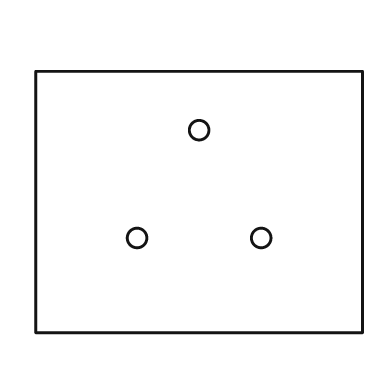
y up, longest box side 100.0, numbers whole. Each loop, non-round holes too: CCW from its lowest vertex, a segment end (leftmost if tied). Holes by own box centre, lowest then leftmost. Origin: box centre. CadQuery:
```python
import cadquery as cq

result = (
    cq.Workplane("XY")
    .moveTo(-50.0, -40.0)
    .lineTo(50.0, -40.0)
    .lineTo(50.0, 40.0)
    .lineTo(-50.0, 40.0)
    .close()
    .moveTo(-19.0, -11.0)
    .circle(3.0)
    .moveTo(19.0, -11.0)
    .circle(3.0)
    .moveTo(0.0, 22.0)
    .circle(3.0)
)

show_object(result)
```